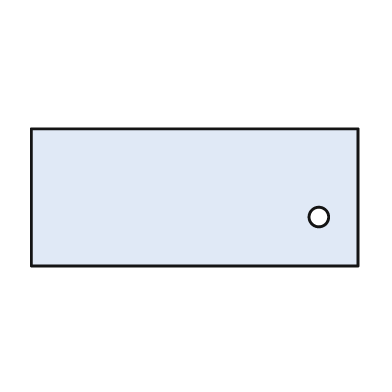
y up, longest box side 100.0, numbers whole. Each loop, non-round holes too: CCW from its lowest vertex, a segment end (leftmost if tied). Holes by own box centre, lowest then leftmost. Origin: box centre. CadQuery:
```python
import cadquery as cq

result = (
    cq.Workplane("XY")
    .moveTo(-50.0, -21.0)
    .lineTo(50.0, -21.0)
    .lineTo(50.0, 21.0)
    .lineTo(-50.0, 21.0)
    .close()
    .moveTo(38.0, -6.0)
    .circle(3.0)
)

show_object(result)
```